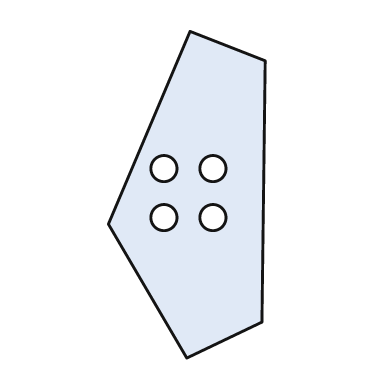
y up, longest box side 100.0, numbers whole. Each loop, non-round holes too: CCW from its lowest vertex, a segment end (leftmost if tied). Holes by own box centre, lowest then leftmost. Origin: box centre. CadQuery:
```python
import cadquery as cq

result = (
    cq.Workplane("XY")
    .moveTo(0.0, -50.0)
    .lineTo(23.0, -39.0)
    .lineTo(24.0, 41.0)
    .lineTo(1.0, 50.0)
    .lineTo(-24.0, -9.0)
    .close()
    .moveTo(-7.0, -7.0)
    .circle(4.0)
    .moveTo(8.0, -7.0)
    .circle(4.0)
    .moveTo(-7.0, 8.0)
    .circle(4.0)
    .moveTo(8.0, 8.0)
    .circle(4.0)
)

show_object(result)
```